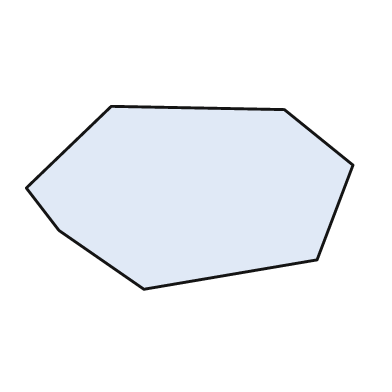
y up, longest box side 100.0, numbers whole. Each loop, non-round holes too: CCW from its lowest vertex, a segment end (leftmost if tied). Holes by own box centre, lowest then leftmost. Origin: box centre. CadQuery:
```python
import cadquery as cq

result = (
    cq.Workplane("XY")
    .moveTo(-14.0, -28.0)
    .lineTo(39.0, -19.0)
    .lineTo(50.0, 10.0)
    .lineTo(29.0, 27.0)
    .lineTo(-24.0, 28.0)
    .lineTo(-50.0, 3.0)
    .lineTo(-40.0, -10.0)
    .close()
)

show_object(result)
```